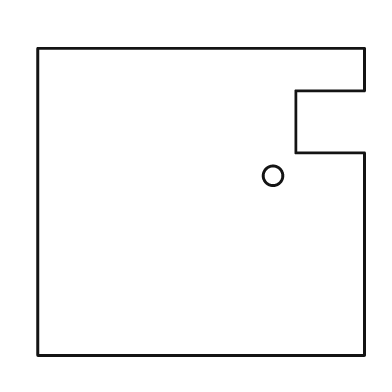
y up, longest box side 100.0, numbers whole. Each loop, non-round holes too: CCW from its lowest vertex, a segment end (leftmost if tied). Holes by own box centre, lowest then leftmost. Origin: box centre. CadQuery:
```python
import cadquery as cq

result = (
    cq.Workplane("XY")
    .moveTo(-50.0, -47.0)
    .lineTo(50.0, -47.0)
    .lineTo(50.0, 15.0)
    .lineTo(29.0, 15.0)
    .lineTo(29.0, 34.0)
    .lineTo(50.0, 34.0)
    .lineTo(50.0, 47.0)
    .lineTo(-50.0, 47.0)
    .close()
    .moveTo(22.0, 8.0)
    .circle(3.0)
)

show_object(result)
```